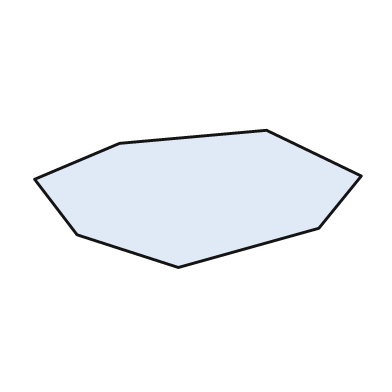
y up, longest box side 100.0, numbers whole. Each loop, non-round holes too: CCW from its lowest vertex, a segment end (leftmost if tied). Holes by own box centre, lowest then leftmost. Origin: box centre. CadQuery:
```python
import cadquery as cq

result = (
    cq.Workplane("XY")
    .moveTo(-6.0, -21.0)
    .lineTo(37.0, -9.0)
    .lineTo(50.0, 7.0)
    .lineTo(21.0, 21.0)
    .lineTo(-24.0, 17.0)
    .lineTo(-50.0, 6.0)
    .lineTo(-37.0, -11.0)
    .close()
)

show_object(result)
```